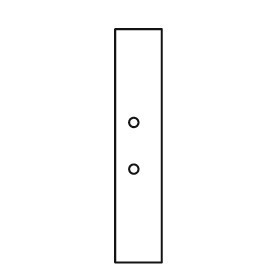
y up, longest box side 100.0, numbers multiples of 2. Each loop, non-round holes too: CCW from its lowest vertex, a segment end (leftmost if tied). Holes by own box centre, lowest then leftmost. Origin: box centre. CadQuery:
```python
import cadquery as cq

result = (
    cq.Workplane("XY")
    .moveTo(-10.0, -50.0)
    .lineTo(10.0, -50.0)
    .lineTo(10.0, 50.0)
    .lineTo(-10.0, 50.0)
    .close()
    .moveTo(-2.0, -10.0)
    .circle(2.0)
    .moveTo(-2.0, 10.0)
    .circle(2.0)
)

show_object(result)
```